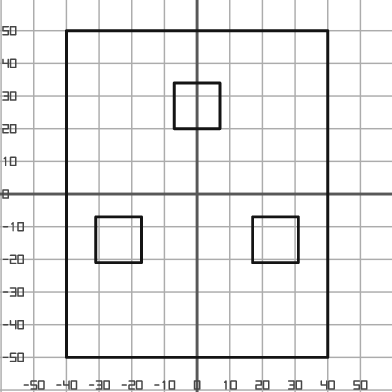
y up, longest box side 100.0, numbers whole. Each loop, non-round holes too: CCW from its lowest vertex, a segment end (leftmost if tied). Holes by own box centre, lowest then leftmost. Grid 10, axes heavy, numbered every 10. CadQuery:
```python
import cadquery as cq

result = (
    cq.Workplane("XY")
    .moveTo(-40.0, -50.0)
    .lineTo(40.0, -50.0)
    .lineTo(40.0, 50.0)
    .lineTo(-40.0, 50.0)
    .close()
    .moveTo(-31.0, -21.0)
    .lineTo(-17.0, -21.0)
    .lineTo(-17.0, -7.0)
    .lineTo(-31.0, -7.0)
    .close()
    .moveTo(17.0, -21.0)
    .lineTo(31.0, -21.0)
    .lineTo(31.0, -7.0)
    .lineTo(17.0, -7.0)
    .close()
    .moveTo(-7.0, 20.0)
    .lineTo(7.0, 20.0)
    .lineTo(7.0, 34.0)
    .lineTo(-7.0, 34.0)
    .close()
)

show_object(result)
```